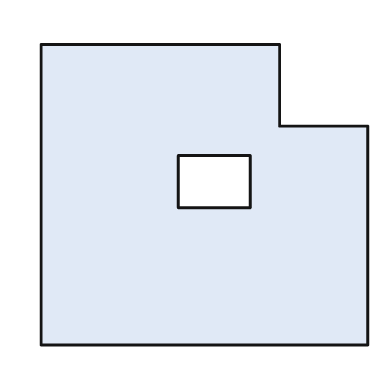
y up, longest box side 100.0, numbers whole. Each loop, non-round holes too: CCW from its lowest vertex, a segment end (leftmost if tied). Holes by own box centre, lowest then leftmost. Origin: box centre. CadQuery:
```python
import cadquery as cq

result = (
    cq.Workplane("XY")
    .moveTo(-50.0, -46.0)
    .lineTo(50.0, -46.0)
    .lineTo(50.0, 21.0)
    .lineTo(23.0, 21.0)
    .lineTo(23.0, 46.0)
    .lineTo(-50.0, 46.0)
    .close()
    .moveTo(-8.0, -4.0)
    .lineTo(14.0, -4.0)
    .lineTo(14.0, 12.0)
    .lineTo(-8.0, 12.0)
    .close()
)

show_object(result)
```